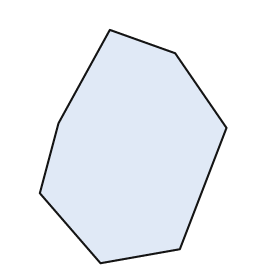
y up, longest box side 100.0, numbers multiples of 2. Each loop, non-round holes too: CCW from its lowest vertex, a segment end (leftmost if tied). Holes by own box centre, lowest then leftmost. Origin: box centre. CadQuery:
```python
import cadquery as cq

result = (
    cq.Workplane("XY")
    .moveTo(-14.0, -50.0)
    .lineTo(20.0, -44.0)
    .lineTo(40.0, 8.0)
    .lineTo(18.0, 40.0)
    .lineTo(-10.0, 50.0)
    .lineTo(-32.0, 10.0)
    .lineTo(-40.0, -20.0)
    .close()
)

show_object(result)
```